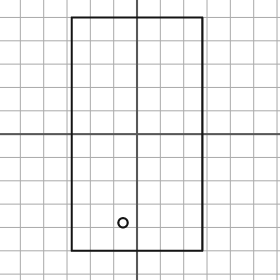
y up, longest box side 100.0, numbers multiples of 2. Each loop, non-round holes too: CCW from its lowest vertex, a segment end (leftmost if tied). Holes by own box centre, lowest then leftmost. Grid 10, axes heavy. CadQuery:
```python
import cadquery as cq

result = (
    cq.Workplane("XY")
    .moveTo(-28.0, -50.0)
    .lineTo(28.0, -50.0)
    .lineTo(28.0, 50.0)
    .lineTo(-28.0, 50.0)
    .close()
    .moveTo(-6.0, -38.0)
    .circle(2.0)
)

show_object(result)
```